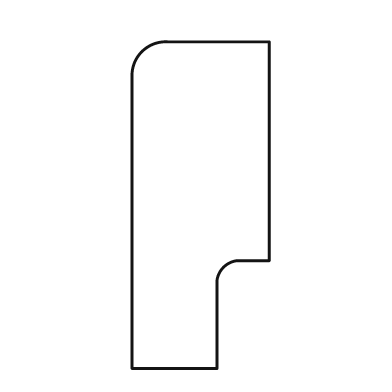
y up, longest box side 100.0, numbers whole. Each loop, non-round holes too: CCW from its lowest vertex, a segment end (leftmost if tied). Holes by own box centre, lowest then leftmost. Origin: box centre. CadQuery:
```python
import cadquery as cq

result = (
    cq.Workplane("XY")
    .moveTo(-21.0, -50.0)
    .lineTo(5.0, -50.0)
    .lineTo(5.0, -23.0)
    .threePointArc((7.0, -19.0), (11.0, -17.0))
    .lineTo(21.0, -17.0)
    .lineTo(21.0, 50.0)
    .lineTo(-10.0, 50.0)
    .threePointArc((-18.0, 47.0), (-21.0, 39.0))
    .close()
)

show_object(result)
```